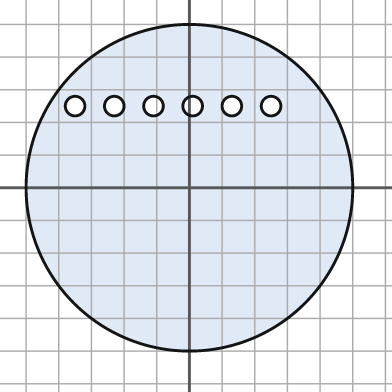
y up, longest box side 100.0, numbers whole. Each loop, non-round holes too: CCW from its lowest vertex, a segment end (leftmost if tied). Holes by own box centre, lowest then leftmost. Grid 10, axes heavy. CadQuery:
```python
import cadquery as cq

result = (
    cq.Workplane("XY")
    .moveTo(0.0, 0.0)
    .circle(50.0)
    .moveTo(-35.0, 25.0)
    .circle(3.0)
    .moveTo(-23.0, 25.0)
    .circle(3.0)
    .moveTo(-11.0, 25.0)
    .circle(3.0)
    .moveTo(1.0, 25.0)
    .circle(3.0)
    .moveTo(13.0, 25.0)
    .circle(3.0)
    .moveTo(25.0, 25.0)
    .circle(3.0)
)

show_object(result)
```